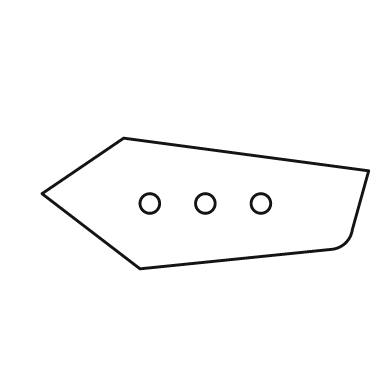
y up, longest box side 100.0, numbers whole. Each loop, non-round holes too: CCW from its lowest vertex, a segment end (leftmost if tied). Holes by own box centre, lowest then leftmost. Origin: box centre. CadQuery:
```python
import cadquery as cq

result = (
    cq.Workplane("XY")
    .moveTo(-20.0, -20.0)
    .lineTo(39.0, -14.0)
    .threePointArc((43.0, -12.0), (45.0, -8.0))
    .lineTo(50.0, 10.0)
    .lineTo(-25.0, 20.0)
    .lineTo(-50.0, 3.0)
    .close()
    .moveTo(-17.0, 0.0)
    .circle(3.0)
    .moveTo(0.0, 0.0)
    .circle(3.0)
    .moveTo(17.0, 0.0)
    .circle(3.0)
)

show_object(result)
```